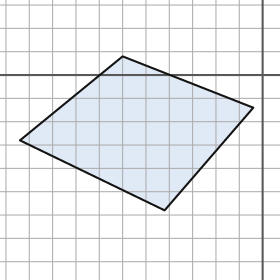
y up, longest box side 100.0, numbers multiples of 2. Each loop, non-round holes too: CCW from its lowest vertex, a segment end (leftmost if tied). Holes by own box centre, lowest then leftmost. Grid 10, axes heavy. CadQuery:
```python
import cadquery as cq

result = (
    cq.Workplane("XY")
    .moveTo(-42.0, -58.0)
    .lineTo(-4.0, -14.0)
    .lineTo(-60.0, 8.0)
    .lineTo(-104.0, -28.0)
    .close()
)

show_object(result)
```